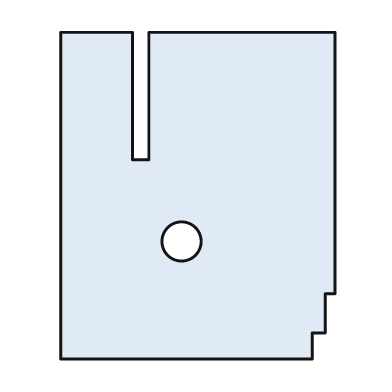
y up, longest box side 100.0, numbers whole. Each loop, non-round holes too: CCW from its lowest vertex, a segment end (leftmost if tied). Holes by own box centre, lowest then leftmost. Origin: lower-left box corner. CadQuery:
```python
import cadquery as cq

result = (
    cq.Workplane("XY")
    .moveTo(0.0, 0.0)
    .lineTo(77.0, 0.0)
    .lineTo(77.0, 8.0)
    .lineTo(81.0, 8.0)
    .lineTo(81.0, 20.0)
    .lineTo(84.0, 20.0)
    .lineTo(84.0, 100.0)
    .lineTo(27.0, 100.0)
    .lineTo(27.0, 61.0)
    .lineTo(22.0, 61.0)
    .lineTo(22.0, 100.0)
    .lineTo(0.0, 100.0)
    .close()
    .moveTo(37.0, 36.0)
    .circle(6.0)
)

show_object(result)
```